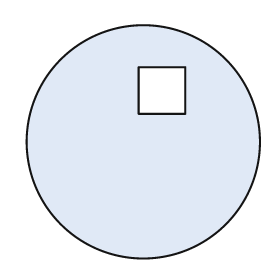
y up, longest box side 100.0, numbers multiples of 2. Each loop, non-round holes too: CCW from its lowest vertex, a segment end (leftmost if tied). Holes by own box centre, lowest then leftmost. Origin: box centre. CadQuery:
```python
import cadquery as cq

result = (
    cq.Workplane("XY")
    .moveTo(0.0, 0.0)
    .circle(50.0)
    .moveTo(-2.0, 12.0)
    .lineTo(18.0, 12.0)
    .lineTo(18.0, 32.0)
    .lineTo(-2.0, 32.0)
    .close()
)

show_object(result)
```